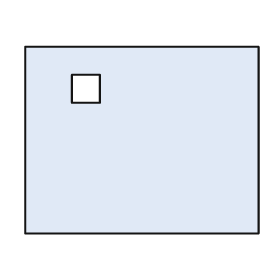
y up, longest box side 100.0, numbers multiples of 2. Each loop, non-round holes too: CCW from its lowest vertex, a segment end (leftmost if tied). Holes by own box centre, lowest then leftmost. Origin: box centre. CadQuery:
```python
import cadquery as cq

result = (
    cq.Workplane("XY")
    .moveTo(-50.0, -40.0)
    .lineTo(50.0, -40.0)
    .lineTo(50.0, 40.0)
    .lineTo(-50.0, 40.0)
    .close()
    .moveTo(-30.0, 16.0)
    .lineTo(-18.0, 16.0)
    .lineTo(-18.0, 28.0)
    .lineTo(-30.0, 28.0)
    .close()
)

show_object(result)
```